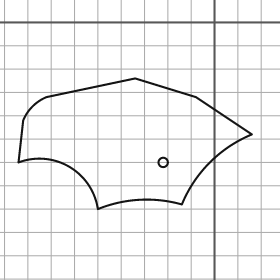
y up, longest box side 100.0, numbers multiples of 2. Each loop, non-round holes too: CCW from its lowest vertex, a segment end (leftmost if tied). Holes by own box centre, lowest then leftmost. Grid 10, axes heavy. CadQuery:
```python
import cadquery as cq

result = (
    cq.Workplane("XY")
    .moveTo(-50.0, -80.0)
    .threePointArc((-32.0, -76.0), (-14.0, -78.0))
    .threePointArc((-2.0, -60.0), (16.0, -48.0))
    .lineTo(-8.0, -32.0)
    .lineTo(-34.0, -24.0)
    .lineTo(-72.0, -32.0)
    .threePointArc((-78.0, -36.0), (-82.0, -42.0))
    .lineTo(-84.0, -60.0)
    .threePointArc((-62.0, -62.0), (-50.0, -80.0))
    .close()
    .moveTo(-22.0, -60.0)
    .circle(2.0)
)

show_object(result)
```